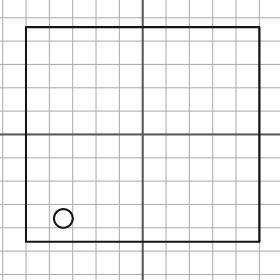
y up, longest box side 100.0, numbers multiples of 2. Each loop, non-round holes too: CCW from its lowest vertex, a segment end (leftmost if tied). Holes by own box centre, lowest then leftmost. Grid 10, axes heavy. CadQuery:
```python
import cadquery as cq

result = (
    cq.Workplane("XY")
    .moveTo(-50.0, -46.0)
    .lineTo(50.0, -46.0)
    .lineTo(50.0, 46.0)
    .lineTo(-50.0, 46.0)
    .close()
    .moveTo(-34.0, -36.0)
    .circle(4.0)
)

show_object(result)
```